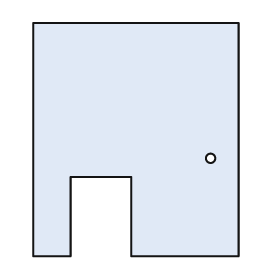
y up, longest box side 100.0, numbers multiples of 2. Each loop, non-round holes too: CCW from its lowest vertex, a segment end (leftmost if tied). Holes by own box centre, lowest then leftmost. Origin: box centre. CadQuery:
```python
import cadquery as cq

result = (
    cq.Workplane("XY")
    .moveTo(-44.0, -50.0)
    .lineTo(-28.0, -50.0)
    .lineTo(-28.0, -16.0)
    .lineTo(-2.0, -16.0)
    .lineTo(-2.0, -50.0)
    .lineTo(44.0, -50.0)
    .lineTo(44.0, 50.0)
    .lineTo(-44.0, 50.0)
    .close()
    .moveTo(32.0, -8.0)
    .circle(2.0)
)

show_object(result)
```